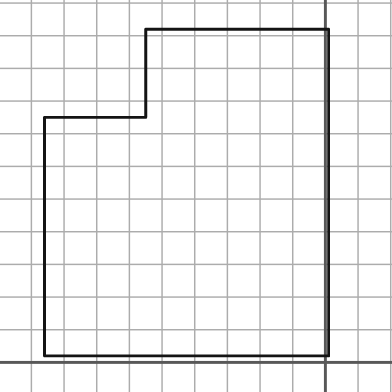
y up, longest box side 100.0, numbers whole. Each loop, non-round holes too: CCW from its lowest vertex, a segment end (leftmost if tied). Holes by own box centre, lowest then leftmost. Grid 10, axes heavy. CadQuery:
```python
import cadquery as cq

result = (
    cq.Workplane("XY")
    .moveTo(-86.0, 2.0)
    .lineTo(1.0, 2.0)
    .lineTo(1.0, 102.0)
    .lineTo(-55.0, 102.0)
    .lineTo(-55.0, 75.0)
    .lineTo(-86.0, 75.0)
    .close()
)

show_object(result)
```